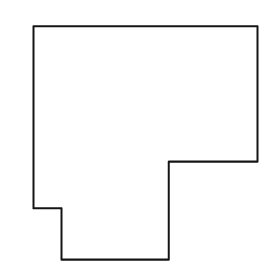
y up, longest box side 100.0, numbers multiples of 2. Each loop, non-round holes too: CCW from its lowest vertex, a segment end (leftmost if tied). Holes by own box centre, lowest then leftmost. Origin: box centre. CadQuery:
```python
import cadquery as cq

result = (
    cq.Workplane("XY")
    .moveTo(-36.0, -50.0)
    .lineTo(10.0, -50.0)
    .lineTo(10.0, -8.0)
    .lineTo(48.0, -8.0)
    .lineTo(48.0, 50.0)
    .lineTo(-48.0, 50.0)
    .lineTo(-48.0, -28.0)
    .lineTo(-36.0, -28.0)
    .close()
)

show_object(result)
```